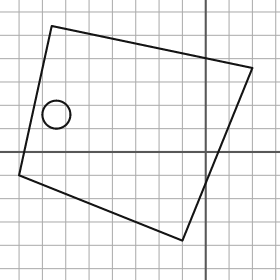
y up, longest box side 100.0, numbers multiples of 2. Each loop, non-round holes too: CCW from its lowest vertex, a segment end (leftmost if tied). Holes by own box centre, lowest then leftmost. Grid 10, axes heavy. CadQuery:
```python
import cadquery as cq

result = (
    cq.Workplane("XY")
    .moveTo(-10.0, -38.0)
    .lineTo(20.0, 36.0)
    .lineTo(-66.0, 54.0)
    .lineTo(-80.0, -10.0)
    .close()
    .moveTo(-64.0, 16.0)
    .circle(6.0)
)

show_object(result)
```